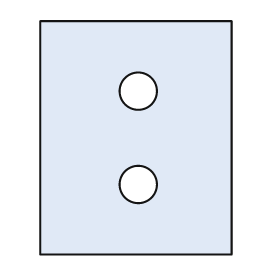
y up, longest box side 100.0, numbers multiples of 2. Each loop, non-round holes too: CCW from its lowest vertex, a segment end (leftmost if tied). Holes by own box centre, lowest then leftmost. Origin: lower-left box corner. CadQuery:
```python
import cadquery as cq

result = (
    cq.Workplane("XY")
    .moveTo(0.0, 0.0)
    .lineTo(82.0, 0.0)
    .lineTo(82.0, 100.0)
    .lineTo(0.0, 100.0)
    .close()
    .moveTo(42.0, 30.0)
    .circle(8.0)
    .moveTo(42.0, 70.0)
    .circle(8.0)
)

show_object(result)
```